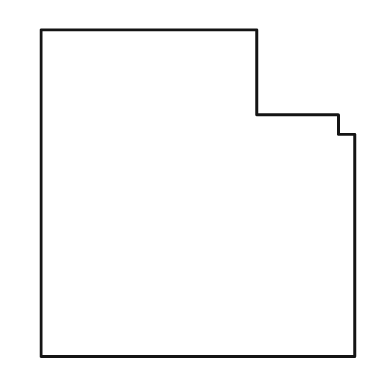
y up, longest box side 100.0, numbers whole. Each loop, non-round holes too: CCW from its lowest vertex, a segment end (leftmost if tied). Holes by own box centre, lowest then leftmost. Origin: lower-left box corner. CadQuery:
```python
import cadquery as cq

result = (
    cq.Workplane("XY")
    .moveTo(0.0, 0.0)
    .lineTo(96.0, 0.0)
    .lineTo(96.0, 68.0)
    .lineTo(91.0, 68.0)
    .lineTo(91.0, 74.0)
    .lineTo(66.0, 74.0)
    .lineTo(66.0, 100.0)
    .lineTo(0.0, 100.0)
    .close()
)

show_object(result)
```